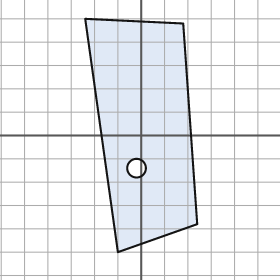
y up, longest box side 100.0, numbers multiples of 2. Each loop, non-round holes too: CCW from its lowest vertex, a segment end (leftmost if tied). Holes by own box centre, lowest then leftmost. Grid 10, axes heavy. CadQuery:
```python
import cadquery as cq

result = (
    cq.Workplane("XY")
    .moveTo(-10.0, -50.0)
    .lineTo(24.0, -38.0)
    .lineTo(18.0, 48.0)
    .lineTo(-24.0, 50.0)
    .close()
    .moveTo(-2.0, -14.0)
    .circle(4.0)
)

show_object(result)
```